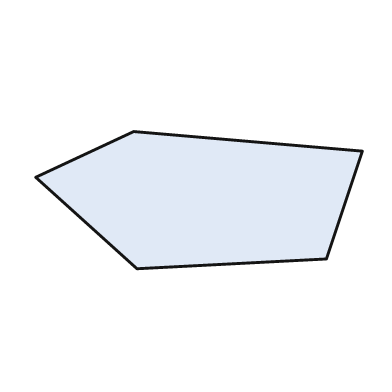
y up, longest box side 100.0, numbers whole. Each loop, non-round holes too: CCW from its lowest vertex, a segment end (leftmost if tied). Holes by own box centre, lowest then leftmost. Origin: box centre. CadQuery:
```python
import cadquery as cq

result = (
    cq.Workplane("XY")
    .moveTo(-19.0, -21.0)
    .lineTo(39.0, -18.0)
    .lineTo(50.0, 15.0)
    .lineTo(-20.0, 21.0)
    .lineTo(-50.0, 7.0)
    .close()
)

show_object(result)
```